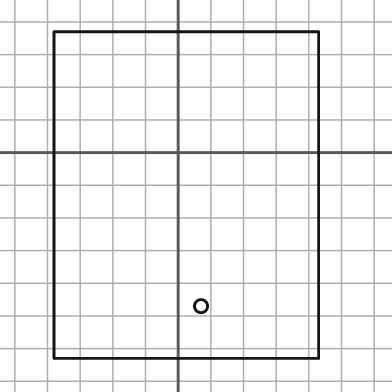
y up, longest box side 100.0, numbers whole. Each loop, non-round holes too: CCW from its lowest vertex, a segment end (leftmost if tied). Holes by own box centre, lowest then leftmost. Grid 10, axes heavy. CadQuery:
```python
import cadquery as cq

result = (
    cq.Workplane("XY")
    .moveTo(-38.0, -63.0)
    .lineTo(43.0, -63.0)
    .lineTo(43.0, 37.0)
    .lineTo(-38.0, 37.0)
    .close()
    .moveTo(7.0, -47.0)
    .circle(2.0)
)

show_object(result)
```